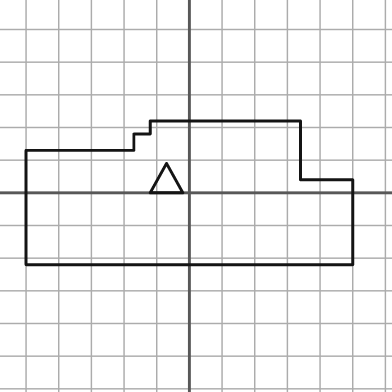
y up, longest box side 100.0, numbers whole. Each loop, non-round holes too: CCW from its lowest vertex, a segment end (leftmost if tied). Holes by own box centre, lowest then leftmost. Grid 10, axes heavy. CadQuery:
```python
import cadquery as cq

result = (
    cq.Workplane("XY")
    .moveTo(-50.0, -22.0)
    .lineTo(50.0, -22.0)
    .lineTo(50.0, 4.0)
    .lineTo(34.0, 4.0)
    .lineTo(34.0, 22.0)
    .lineTo(-12.0, 22.0)
    .lineTo(-12.0, 18.0)
    .lineTo(-17.0, 18.0)
    .lineTo(-17.0, 13.0)
    .lineTo(-50.0, 13.0)
    .close()
    .moveTo(-12.0, 0.0)
    .lineTo(-2.0, 0.0)
    .lineTo(-7.0, 9.0)
    .close()
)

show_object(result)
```